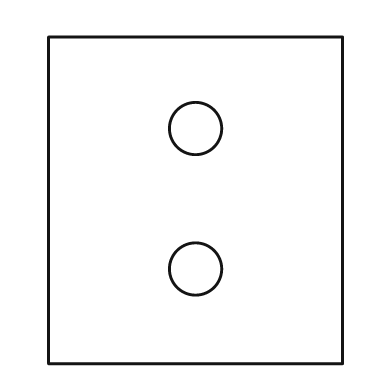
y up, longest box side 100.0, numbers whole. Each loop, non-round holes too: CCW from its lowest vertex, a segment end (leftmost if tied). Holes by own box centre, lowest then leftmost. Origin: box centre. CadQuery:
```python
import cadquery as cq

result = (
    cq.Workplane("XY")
    .moveTo(-45.0, -50.0)
    .lineTo(45.0, -50.0)
    .lineTo(45.0, 50.0)
    .lineTo(-45.0, 50.0)
    .close()
    .moveTo(0.0, -21.0)
    .circle(8.0)
    .moveTo(0.0, 22.0)
    .circle(8.0)
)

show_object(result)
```